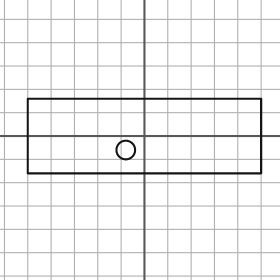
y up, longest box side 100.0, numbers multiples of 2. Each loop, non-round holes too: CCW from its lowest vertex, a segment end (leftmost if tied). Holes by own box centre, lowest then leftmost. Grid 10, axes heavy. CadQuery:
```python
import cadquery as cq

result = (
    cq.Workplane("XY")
    .moveTo(-50.0, -16.0)
    .lineTo(50.0, -16.0)
    .lineTo(50.0, 16.0)
    .lineTo(-50.0, 16.0)
    .close()
    .moveTo(-8.0, -6.0)
    .circle(4.0)
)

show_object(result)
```